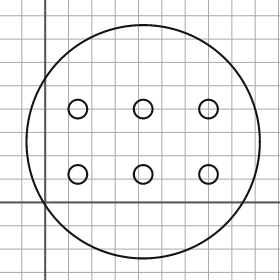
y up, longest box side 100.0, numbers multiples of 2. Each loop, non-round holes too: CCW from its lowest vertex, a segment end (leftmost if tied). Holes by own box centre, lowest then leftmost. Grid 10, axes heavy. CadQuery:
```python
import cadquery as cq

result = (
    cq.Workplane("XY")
    .moveTo(42.0, 26.0)
    .circle(50.0)
    .moveTo(14.0, 12.0)
    .circle(4.0)
    .moveTo(42.0, 12.0)
    .circle(4.0)
    .moveTo(70.0, 12.0)
    .circle(4.0)
    .moveTo(14.0, 40.0)
    .circle(4.0)
    .moveTo(42.0, 40.0)
    .circle(4.0)
    .moveTo(70.0, 40.0)
    .circle(4.0)
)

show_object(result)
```